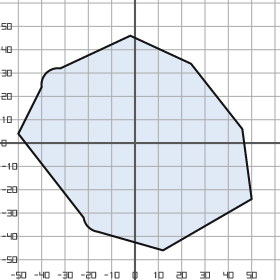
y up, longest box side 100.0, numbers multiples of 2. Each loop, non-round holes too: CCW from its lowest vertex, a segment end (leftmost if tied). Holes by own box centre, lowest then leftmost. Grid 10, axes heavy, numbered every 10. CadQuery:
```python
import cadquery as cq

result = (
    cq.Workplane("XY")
    .moveTo(12.0, -46.0)
    .lineTo(50.0, -24.0)
    .lineTo(46.0, 6.0)
    .lineTo(24.0, 34.0)
    .lineTo(-2.0, 46.0)
    .lineTo(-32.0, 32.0)
    .threePointArc((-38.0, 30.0), (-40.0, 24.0))
    .lineTo(-50.0, 4.0)
    .lineTo(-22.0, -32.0)
    .threePointArc((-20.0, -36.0), (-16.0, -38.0))
    .close()
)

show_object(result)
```